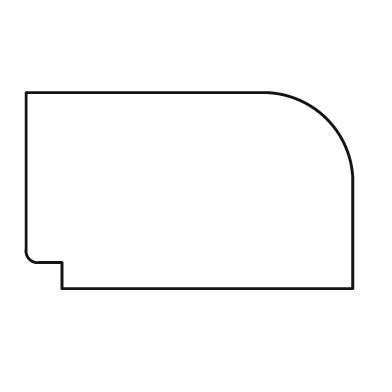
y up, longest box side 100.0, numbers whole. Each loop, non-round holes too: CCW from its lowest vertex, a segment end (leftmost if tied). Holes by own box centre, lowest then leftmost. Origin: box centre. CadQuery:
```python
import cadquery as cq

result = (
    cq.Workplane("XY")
    .moveTo(-39.0, -30.0)
    .lineTo(50.0, -30.0)
    .lineTo(50.0, 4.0)
    .threePointArc((42.0, 22.0), (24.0, 30.0))
    .lineTo(-50.0, 30.0)
    .lineTo(-50.0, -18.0)
    .threePointArc((-49.0, -21.0), (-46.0, -22.0))
    .lineTo(-39.0, -22.0)
    .close()
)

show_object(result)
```